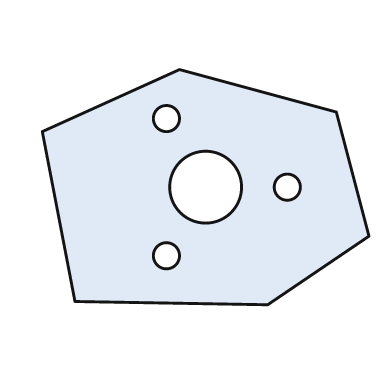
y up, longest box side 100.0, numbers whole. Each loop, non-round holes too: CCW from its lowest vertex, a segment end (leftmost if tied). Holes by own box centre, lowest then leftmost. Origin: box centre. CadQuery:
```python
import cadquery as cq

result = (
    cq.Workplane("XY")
    .moveTo(19.0, -36.0)
    .lineTo(50.0, -15.0)
    .lineTo(40.0, 23.0)
    .lineTo(-8.0, 36.0)
    .lineTo(-50.0, 17.0)
    .lineTo(-40.0, -35.0)
    .close()
    .moveTo(-12.0, -21.0)
    .circle(4.0)
    .moveTo(0.0, 0.0)
    .circle(11.0)
    .moveTo(25.0, 0.0)
    .circle(4.0)
    .moveTo(-12.0, 21.0)
    .circle(4.0)
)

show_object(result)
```